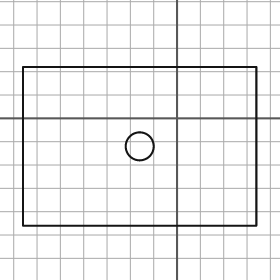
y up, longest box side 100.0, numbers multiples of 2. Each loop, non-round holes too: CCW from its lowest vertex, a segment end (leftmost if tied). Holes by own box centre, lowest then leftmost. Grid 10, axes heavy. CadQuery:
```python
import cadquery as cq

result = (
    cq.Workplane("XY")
    .moveTo(-66.0, -46.0)
    .lineTo(34.0, -46.0)
    .lineTo(34.0, 22.0)
    .lineTo(-66.0, 22.0)
    .close()
    .moveTo(-16.0, -12.0)
    .circle(6.0)
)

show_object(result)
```